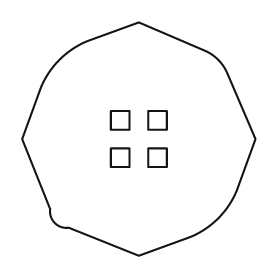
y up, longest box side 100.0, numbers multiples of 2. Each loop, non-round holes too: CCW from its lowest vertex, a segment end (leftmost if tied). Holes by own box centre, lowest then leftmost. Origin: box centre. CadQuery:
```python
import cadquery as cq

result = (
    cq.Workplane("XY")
    .moveTo(0.0, -50.0)
    .lineTo(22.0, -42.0)
    .threePointArc((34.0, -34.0), (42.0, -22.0))
    .lineTo(50.0, 0.0)
    .lineTo(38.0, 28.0)
    .threePointArc((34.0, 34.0), (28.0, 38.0))
    .lineTo(0.0, 50.0)
    .lineTo(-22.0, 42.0)
    .threePointArc((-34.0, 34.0), (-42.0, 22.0))
    .lineTo(-50.0, 0.0)
    .lineTo(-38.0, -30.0)
    .threePointArc((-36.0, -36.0), (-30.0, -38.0))
    .close()
    .moveTo(-12.0, -12.0)
    .lineTo(-4.0, -12.0)
    .lineTo(-4.0, -4.0)
    .lineTo(-12.0, -4.0)
    .close()
    .moveTo(4.0, -12.0)
    .lineTo(12.0, -12.0)
    .lineTo(12.0, -4.0)
    .lineTo(4.0, -4.0)
    .close()
    .moveTo(-12.0, 4.0)
    .lineTo(-4.0, 4.0)
    .lineTo(-4.0, 12.0)
    .lineTo(-12.0, 12.0)
    .close()
    .moveTo(4.0, 4.0)
    .lineTo(12.0, 4.0)
    .lineTo(12.0, 12.0)
    .lineTo(4.0, 12.0)
    .close()
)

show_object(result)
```